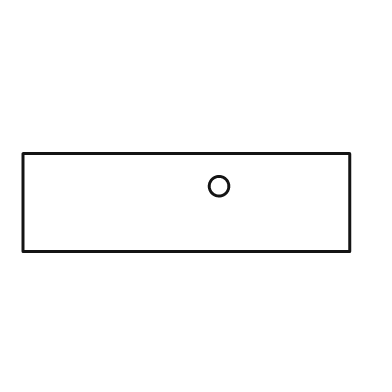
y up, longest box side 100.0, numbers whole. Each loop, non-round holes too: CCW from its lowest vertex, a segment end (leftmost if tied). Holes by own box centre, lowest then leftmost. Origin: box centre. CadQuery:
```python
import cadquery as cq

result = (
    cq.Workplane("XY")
    .moveTo(-50.0, -15.0)
    .lineTo(50.0, -15.0)
    .lineTo(50.0, 15.0)
    .lineTo(-50.0, 15.0)
    .close()
    .moveTo(10.0, 5.0)
    .circle(3.0)
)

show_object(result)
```